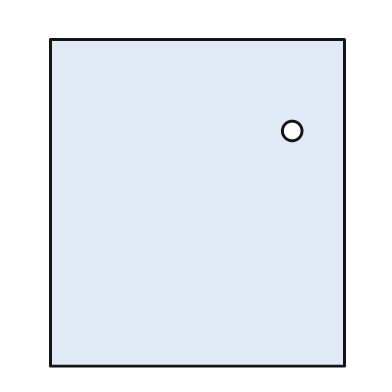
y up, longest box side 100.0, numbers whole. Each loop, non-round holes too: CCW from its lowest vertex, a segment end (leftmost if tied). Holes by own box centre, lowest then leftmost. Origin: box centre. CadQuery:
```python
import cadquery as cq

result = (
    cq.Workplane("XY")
    .moveTo(-45.0, -50.0)
    .lineTo(45.0, -50.0)
    .lineTo(45.0, 50.0)
    .lineTo(-45.0, 50.0)
    .close()
    .moveTo(29.0, 22.0)
    .circle(3.0)
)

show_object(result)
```